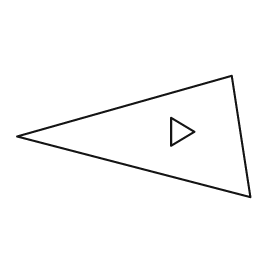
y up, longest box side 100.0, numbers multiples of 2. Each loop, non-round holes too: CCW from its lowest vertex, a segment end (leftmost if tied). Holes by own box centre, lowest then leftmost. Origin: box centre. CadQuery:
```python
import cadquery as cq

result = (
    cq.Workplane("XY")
    .moveTo(50.0, -26.0)
    .lineTo(42.0, 26.0)
    .lineTo(-50.0, 0.0)
    .close()
    .moveTo(16.0, -4.0)
    .lineTo(26.0, 2.0)
    .lineTo(16.0, 8.0)
    .close()
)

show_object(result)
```